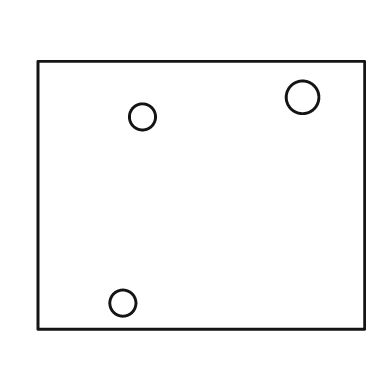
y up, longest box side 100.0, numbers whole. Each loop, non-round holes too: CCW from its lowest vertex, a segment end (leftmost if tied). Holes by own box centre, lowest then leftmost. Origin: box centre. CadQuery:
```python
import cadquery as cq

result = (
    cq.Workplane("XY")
    .moveTo(-50.0, -41.0)
    .lineTo(50.0, -41.0)
    .lineTo(50.0, 41.0)
    .lineTo(-50.0, 41.0)
    .close()
    .moveTo(-24.0, -33.0)
    .circle(4.0)
    .moveTo(-18.0, 24.0)
    .circle(4.0)
    .moveTo(31.0, 30.0)
    .circle(5.0)
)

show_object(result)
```